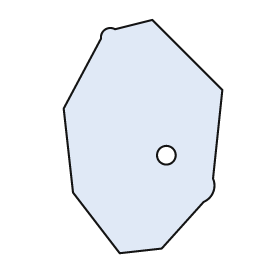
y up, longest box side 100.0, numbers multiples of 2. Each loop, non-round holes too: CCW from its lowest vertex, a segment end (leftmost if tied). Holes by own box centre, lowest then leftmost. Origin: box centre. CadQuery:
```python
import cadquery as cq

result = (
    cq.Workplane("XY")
    .moveTo(-10.0, -50.0)
    .lineTo(8.0, -48.0)
    .lineTo(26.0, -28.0)
    .threePointArc((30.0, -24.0), (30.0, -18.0))
    .lineTo(34.0, 20.0)
    .lineTo(4.0, 50.0)
    .lineTo(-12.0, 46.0)
    .threePointArc((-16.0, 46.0), (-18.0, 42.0))
    .lineTo(-34.0, 12.0)
    .lineTo(-30.0, -24.0)
    .close()
    .moveTo(10.0, -8.0)
    .circle(4.0)
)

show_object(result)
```